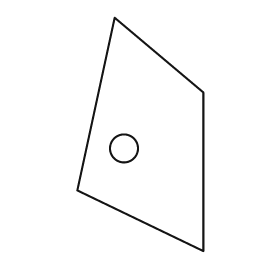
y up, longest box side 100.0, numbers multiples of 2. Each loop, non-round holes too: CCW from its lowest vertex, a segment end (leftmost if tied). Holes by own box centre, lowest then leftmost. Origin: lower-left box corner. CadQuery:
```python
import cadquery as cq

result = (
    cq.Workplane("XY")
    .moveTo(54.0, 0.0)
    .lineTo(54.0, 68.0)
    .lineTo(16.0, 100.0)
    .lineTo(0.0, 26.0)
    .close()
    .moveTo(20.0, 44.0)
    .circle(6.0)
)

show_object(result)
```